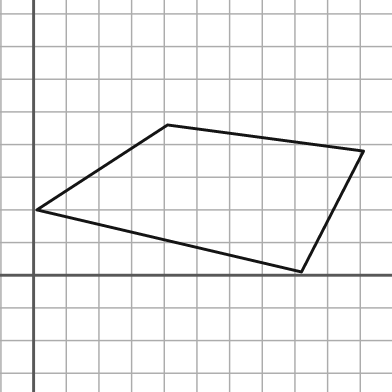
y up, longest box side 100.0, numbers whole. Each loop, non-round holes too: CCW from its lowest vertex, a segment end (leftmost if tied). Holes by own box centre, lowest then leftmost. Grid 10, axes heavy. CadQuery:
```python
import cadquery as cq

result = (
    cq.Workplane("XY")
    .moveTo(82.0, 1.0)
    .lineTo(101.0, 38.0)
    .lineTo(41.0, 46.0)
    .lineTo(1.0, 20.0)
    .close()
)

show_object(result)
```